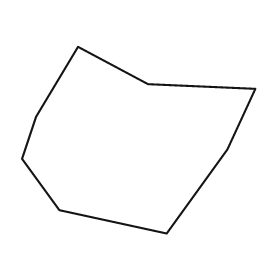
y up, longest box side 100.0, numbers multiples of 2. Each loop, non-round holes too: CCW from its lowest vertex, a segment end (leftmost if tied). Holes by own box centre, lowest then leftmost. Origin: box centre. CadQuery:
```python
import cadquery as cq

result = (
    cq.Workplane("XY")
    .moveTo(12.0, -40.0)
    .lineTo(38.0, -4.0)
    .lineTo(50.0, 22.0)
    .lineTo(4.0, 24.0)
    .lineTo(-26.0, 40.0)
    .lineTo(-44.0, 10.0)
    .lineTo(-50.0, -8.0)
    .lineTo(-34.0, -30.0)
    .close()
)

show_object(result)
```